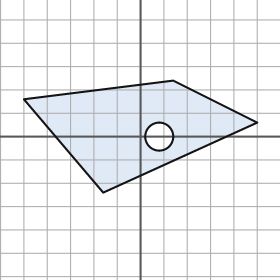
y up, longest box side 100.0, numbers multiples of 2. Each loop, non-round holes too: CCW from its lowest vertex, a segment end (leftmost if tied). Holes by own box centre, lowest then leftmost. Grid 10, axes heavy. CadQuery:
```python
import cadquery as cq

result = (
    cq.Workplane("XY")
    .moveTo(-16.0, -24.0)
    .lineTo(50.0, 6.0)
    .lineTo(14.0, 24.0)
    .lineTo(-50.0, 16.0)
    .close()
    .moveTo(8.0, 0.0)
    .circle(6.0)
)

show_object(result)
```